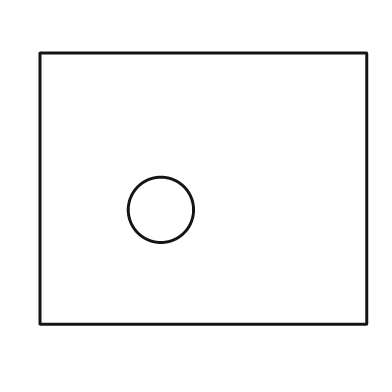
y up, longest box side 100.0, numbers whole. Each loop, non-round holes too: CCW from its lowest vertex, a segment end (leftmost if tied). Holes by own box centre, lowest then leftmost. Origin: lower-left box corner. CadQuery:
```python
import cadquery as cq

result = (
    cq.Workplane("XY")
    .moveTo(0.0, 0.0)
    .lineTo(100.0, 0.0)
    .lineTo(100.0, 83.0)
    .lineTo(0.0, 83.0)
    .close()
    .moveTo(37.0, 35.0)
    .circle(10.0)
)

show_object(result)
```